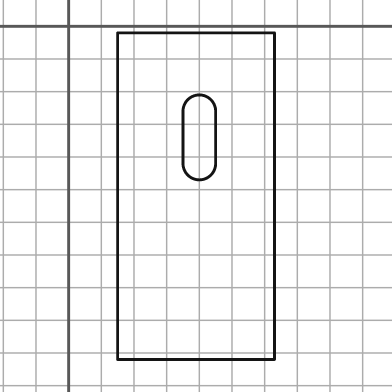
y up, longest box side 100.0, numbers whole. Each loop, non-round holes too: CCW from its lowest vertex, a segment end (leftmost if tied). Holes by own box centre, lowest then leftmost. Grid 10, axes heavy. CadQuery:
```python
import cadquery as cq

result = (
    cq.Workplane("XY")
    .moveTo(15.0, -102.0)
    .lineTo(63.0, -102.0)
    .lineTo(63.0, -2.0)
    .lineTo(15.0, -2.0)
    .close()
    .moveTo(35.0, -42.0)
    .threePointArc((40.0, -47.0), (45.0, -42.0))
    .lineTo(45.0, -26.0)
    .threePointArc((40.0, -21.0), (35.0, -26.0))
    .close()
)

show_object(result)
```